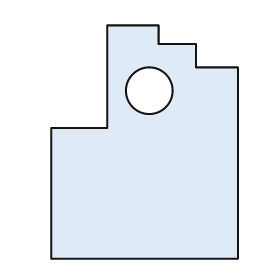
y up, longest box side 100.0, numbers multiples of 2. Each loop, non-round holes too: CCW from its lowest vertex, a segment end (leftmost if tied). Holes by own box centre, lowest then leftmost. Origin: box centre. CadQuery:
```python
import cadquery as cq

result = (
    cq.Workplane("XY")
    .moveTo(-40.0, -50.0)
    .lineTo(40.0, -50.0)
    .lineTo(40.0, 32.0)
    .lineTo(22.0, 32.0)
    .lineTo(22.0, 42.0)
    .lineTo(6.0, 42.0)
    .lineTo(6.0, 50.0)
    .lineTo(-16.0, 50.0)
    .lineTo(-16.0, 6.0)
    .lineTo(-40.0, 6.0)
    .close()
    .moveTo(2.0, 22.0)
    .circle(10.0)
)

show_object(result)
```